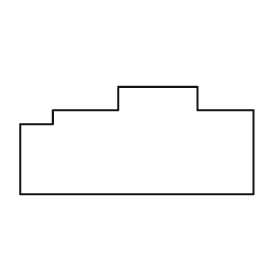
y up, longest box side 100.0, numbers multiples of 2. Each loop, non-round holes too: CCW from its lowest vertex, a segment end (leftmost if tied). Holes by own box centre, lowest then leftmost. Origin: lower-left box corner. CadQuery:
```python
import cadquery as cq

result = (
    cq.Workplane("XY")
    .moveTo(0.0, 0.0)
    .lineTo(100.0, 0.0)
    .lineTo(100.0, 36.0)
    .lineTo(76.0, 36.0)
    .lineTo(76.0, 46.0)
    .lineTo(42.0, 46.0)
    .lineTo(42.0, 36.0)
    .lineTo(14.0, 36.0)
    .lineTo(14.0, 30.0)
    .lineTo(0.0, 30.0)
    .close()
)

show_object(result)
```